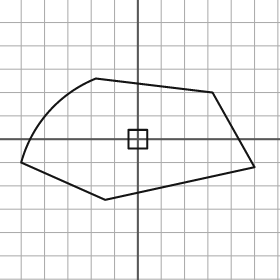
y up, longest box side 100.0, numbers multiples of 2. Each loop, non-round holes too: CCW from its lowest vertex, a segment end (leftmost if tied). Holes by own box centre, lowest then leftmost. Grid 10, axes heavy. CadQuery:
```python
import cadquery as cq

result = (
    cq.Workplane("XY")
    .moveTo(-14.0, -26.0)
    .lineTo(50.0, -12.0)
    .lineTo(32.0, 20.0)
    .lineTo(-18.0, 26.0)
    .threePointArc((-38.0, 12.0), (-50.0, -10.0))
    .close()
    .moveTo(-4.0, -4.0)
    .lineTo(4.0, -4.0)
    .lineTo(4.0, 4.0)
    .lineTo(-4.0, 4.0)
    .close()
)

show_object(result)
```